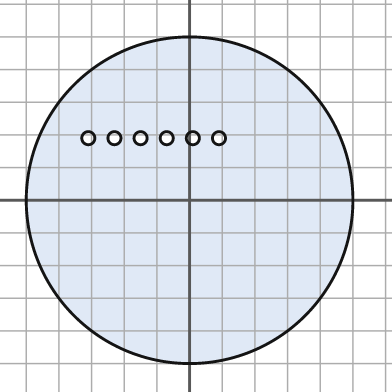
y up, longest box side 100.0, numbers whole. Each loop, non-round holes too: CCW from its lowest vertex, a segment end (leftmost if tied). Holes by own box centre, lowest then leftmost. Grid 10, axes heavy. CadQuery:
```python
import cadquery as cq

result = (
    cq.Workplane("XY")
    .moveTo(0.0, 0.0)
    .circle(50.0)
    .moveTo(-31.0, 19.0)
    .circle(2.0)
    .moveTo(-23.0, 19.0)
    .circle(2.0)
    .moveTo(-15.0, 19.0)
    .circle(2.0)
    .moveTo(-7.0, 19.0)
    .circle(2.0)
    .moveTo(1.0, 19.0)
    .circle(2.0)
    .moveTo(9.0, 19.0)
    .circle(2.0)
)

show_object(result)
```